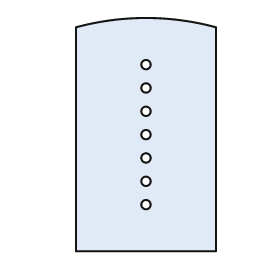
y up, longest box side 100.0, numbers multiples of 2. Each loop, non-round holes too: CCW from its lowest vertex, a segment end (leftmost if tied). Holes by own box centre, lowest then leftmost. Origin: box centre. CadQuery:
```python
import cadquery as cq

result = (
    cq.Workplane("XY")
    .moveTo(-30.0, -50.0)
    .lineTo(30.0, -50.0)
    .lineTo(30.0, 46.0)
    .threePointArc((0.0, 50.0), (-30.0, 46.0))
    .close()
    .moveTo(0.0, -30.0)
    .circle(2.0)
    .moveTo(0.0, -20.0)
    .circle(2.0)
    .moveTo(0.0, -10.0)
    .circle(2.0)
    .moveTo(0.0, 0.0)
    .circle(2.0)
    .moveTo(0.0, 10.0)
    .circle(2.0)
    .moveTo(0.0, 20.0)
    .circle(2.0)
    .moveTo(0.0, 30.0)
    .circle(2.0)
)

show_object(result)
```